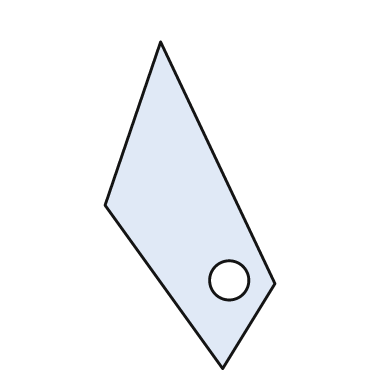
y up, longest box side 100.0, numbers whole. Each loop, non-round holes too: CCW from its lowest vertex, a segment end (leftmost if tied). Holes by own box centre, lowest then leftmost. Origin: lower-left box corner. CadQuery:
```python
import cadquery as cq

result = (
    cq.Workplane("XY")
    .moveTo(36.0, 0.0)
    .lineTo(52.0, 26.0)
    .lineTo(17.0, 100.0)
    .lineTo(0.0, 50.0)
    .close()
    .moveTo(38.0, 27.0)
    .circle(6.0)
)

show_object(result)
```